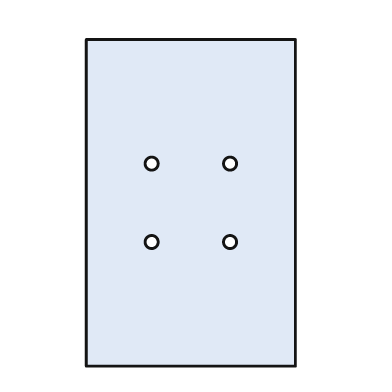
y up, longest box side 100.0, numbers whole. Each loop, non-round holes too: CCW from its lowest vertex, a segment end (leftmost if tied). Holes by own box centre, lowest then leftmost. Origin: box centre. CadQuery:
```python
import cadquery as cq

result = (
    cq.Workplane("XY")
    .moveTo(-32.0, -50.0)
    .lineTo(32.0, -50.0)
    .lineTo(32.0, 50.0)
    .lineTo(-32.0, 50.0)
    .close()
    .moveTo(-12.0, -12.0)
    .circle(2.0)
    .moveTo(12.0, -12.0)
    .circle(2.0)
    .moveTo(-12.0, 12.0)
    .circle(2.0)
    .moveTo(12.0, 12.0)
    .circle(2.0)
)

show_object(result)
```